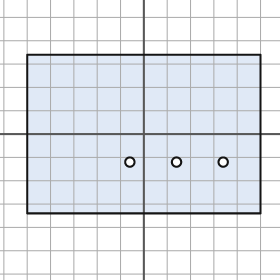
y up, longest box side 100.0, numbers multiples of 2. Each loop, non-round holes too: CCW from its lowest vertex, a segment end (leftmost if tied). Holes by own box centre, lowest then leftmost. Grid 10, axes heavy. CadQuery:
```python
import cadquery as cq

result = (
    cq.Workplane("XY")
    .moveTo(-50.0, -34.0)
    .lineTo(50.0, -34.0)
    .lineTo(50.0, 34.0)
    .lineTo(-50.0, 34.0)
    .close()
    .moveTo(-6.0, -12.0)
    .circle(2.0)
    .moveTo(14.0, -12.0)
    .circle(2.0)
    .moveTo(34.0, -12.0)
    .circle(2.0)
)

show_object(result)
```